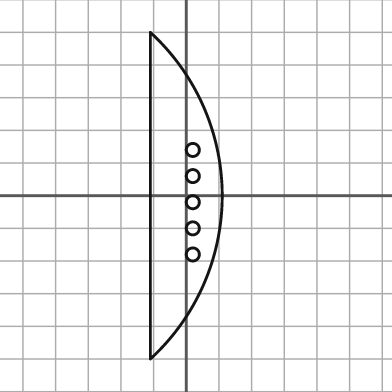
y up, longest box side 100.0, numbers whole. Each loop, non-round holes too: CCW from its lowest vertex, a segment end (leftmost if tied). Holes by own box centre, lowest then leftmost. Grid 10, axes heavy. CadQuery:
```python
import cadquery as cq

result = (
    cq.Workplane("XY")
    .moveTo(-11.0, -50.0)
    .threePointArc((11.0, 0.0), (-11.0, 50.0))
    .close()
    .moveTo(2.0, -18.0)
    .circle(2.0)
    .moveTo(2.0, -10.0)
    .circle(2.0)
    .moveTo(2.0, -2.0)
    .circle(2.0)
    .moveTo(2.0, 6.0)
    .circle(2.0)
    .moveTo(2.0, 14.0)
    .circle(2.0)
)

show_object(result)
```